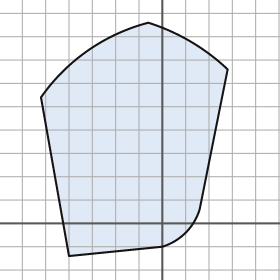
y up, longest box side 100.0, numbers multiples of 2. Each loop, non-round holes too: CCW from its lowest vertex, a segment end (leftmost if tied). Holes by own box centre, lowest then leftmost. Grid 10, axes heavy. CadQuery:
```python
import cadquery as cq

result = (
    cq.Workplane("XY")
    .moveTo(-40.0, -14.0)
    .lineTo(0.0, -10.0)
    .threePointArc((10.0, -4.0), (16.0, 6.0))
    .lineTo(28.0, 66.0)
    .threePointArc((12.0, 78.0), (-6.0, 86.0))
    .threePointArc((-32.0, 74.0), (-52.0, 54.0))
    .close()
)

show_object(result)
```